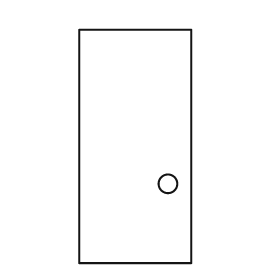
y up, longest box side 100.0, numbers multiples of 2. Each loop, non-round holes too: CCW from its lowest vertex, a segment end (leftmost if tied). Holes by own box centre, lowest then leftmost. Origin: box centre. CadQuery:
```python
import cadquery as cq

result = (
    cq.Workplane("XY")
    .moveTo(-24.0, -50.0)
    .lineTo(24.0, -50.0)
    .lineTo(24.0, 50.0)
    .lineTo(-24.0, 50.0)
    .close()
    .moveTo(14.0, -16.0)
    .circle(4.0)
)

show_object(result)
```